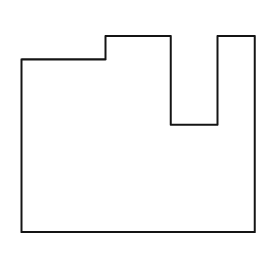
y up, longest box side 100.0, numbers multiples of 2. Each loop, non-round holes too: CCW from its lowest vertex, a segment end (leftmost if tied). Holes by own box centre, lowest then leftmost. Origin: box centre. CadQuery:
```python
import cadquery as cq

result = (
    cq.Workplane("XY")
    .moveTo(-50.0, -42.0)
    .lineTo(50.0, -42.0)
    .lineTo(50.0, 42.0)
    .lineTo(34.0, 42.0)
    .lineTo(34.0, 4.0)
    .lineTo(14.0, 4.0)
    .lineTo(14.0, 42.0)
    .lineTo(-14.0, 42.0)
    .lineTo(-14.0, 32.0)
    .lineTo(-50.0, 32.0)
    .close()
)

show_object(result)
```